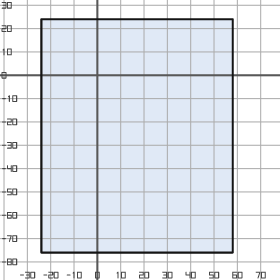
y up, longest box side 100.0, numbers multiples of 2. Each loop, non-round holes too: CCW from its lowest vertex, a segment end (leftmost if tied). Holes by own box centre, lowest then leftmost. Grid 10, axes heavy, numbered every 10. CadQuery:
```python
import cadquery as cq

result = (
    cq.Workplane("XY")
    .moveTo(-24.0, -76.0)
    .lineTo(58.0, -76.0)
    .lineTo(58.0, 24.0)
    .lineTo(-24.0, 24.0)
    .close()
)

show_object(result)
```